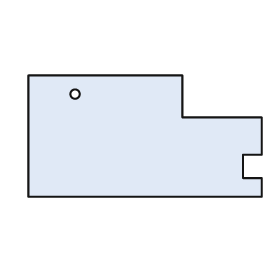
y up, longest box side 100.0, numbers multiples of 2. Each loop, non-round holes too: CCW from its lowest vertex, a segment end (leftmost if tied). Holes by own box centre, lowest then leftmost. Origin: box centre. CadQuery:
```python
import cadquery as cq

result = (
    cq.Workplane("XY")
    .moveTo(-50.0, -26.0)
    .lineTo(50.0, -26.0)
    .lineTo(50.0, -18.0)
    .lineTo(42.0, -18.0)
    .lineTo(42.0, -8.0)
    .lineTo(50.0, -8.0)
    .lineTo(50.0, 8.0)
    .lineTo(16.0, 8.0)
    .lineTo(16.0, 26.0)
    .lineTo(-50.0, 26.0)
    .close()
    .moveTo(-30.0, 18.0)
    .circle(2.0)
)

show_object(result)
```